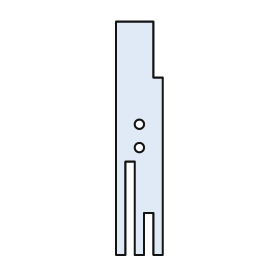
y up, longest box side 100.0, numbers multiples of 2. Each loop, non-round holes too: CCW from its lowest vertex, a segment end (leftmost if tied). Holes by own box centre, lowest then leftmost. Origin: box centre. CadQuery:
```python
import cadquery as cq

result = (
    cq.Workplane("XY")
    .moveTo(-10.0, -50.0)
    .lineTo(-6.0, -50.0)
    .lineTo(-6.0, -10.0)
    .lineTo(-2.0, -10.0)
    .lineTo(-2.0, -50.0)
    .lineTo(2.0, -50.0)
    .lineTo(2.0, -32.0)
    .lineTo(6.0, -32.0)
    .lineTo(6.0, -50.0)
    .lineTo(10.0, -50.0)
    .lineTo(10.0, 26.0)
    .lineTo(6.0, 26.0)
    .lineTo(6.0, 50.0)
    .lineTo(-10.0, 50.0)
    .close()
    .moveTo(0.0, -4.0)
    .circle(2.0)
    .moveTo(0.0, 6.0)
    .circle(2.0)
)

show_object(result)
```